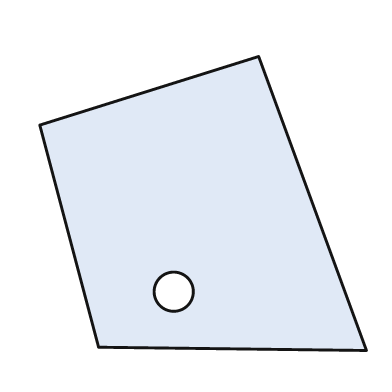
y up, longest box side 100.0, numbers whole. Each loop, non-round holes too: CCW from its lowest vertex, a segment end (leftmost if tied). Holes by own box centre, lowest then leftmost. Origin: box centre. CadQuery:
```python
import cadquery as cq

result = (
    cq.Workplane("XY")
    .moveTo(50.0, -45.0)
    .lineTo(17.0, 45.0)
    .lineTo(-50.0, 24.0)
    .lineTo(-32.0, -44.0)
    .close()
    .moveTo(-9.0, -27.0)
    .circle(6.0)
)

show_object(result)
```